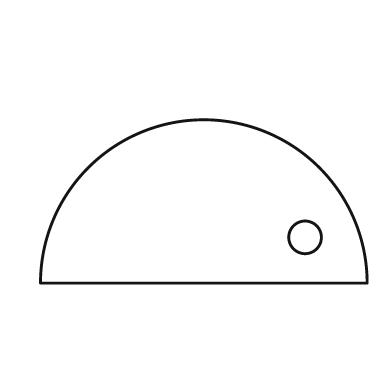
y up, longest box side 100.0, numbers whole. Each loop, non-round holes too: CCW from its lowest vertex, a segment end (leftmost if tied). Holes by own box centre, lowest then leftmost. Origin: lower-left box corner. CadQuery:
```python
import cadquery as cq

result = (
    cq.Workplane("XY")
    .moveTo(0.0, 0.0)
    .lineTo(100.0, 0.0)
    .threePointArc((50.0, 50.0), (0.0, 0.0))
    .close()
    .moveTo(81.0, 14.0)
    .circle(5.0)
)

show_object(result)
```